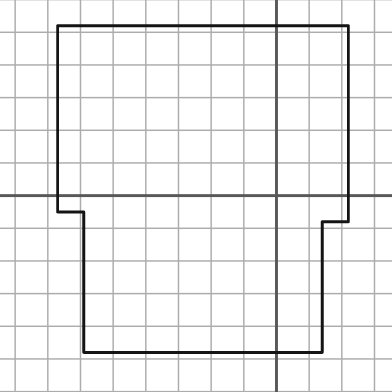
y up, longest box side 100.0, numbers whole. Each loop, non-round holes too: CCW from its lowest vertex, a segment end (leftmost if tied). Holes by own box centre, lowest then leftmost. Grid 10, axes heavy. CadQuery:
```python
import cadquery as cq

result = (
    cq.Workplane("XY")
    .moveTo(-59.0, -48.0)
    .lineTo(14.0, -48.0)
    .lineTo(14.0, -8.0)
    .lineTo(22.0, -8.0)
    .lineTo(22.0, 52.0)
    .lineTo(-67.0, 52.0)
    .lineTo(-67.0, -5.0)
    .lineTo(-59.0, -5.0)
    .close()
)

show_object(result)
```